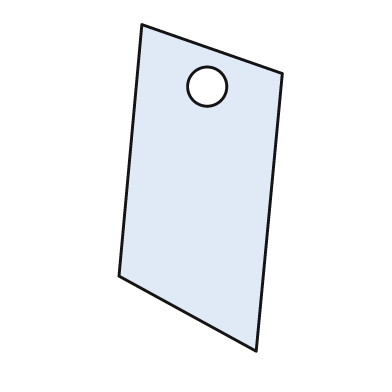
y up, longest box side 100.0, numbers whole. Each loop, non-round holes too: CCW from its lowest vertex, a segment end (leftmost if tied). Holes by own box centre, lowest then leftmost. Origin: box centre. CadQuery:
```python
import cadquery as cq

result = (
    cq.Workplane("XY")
    .moveTo(17.0, -50.0)
    .lineTo(25.0, 35.0)
    .lineTo(-18.0, 50.0)
    .lineTo(-25.0, -27.0)
    .close()
    .moveTo(2.0, 31.0)
    .circle(6.0)
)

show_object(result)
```